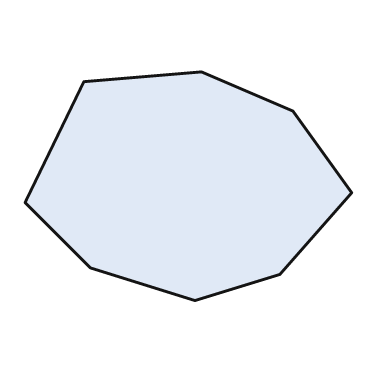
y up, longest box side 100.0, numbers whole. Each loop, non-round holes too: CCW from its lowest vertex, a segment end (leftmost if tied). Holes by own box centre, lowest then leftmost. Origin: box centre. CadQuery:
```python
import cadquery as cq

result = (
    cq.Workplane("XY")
    .moveTo(2.0, -35.0)
    .lineTo(28.0, -27.0)
    .lineTo(50.0, -2.0)
    .lineTo(32.0, 23.0)
    .lineTo(4.0, 35.0)
    .lineTo(-32.0, 32.0)
    .lineTo(-50.0, -5.0)
    .lineTo(-30.0, -25.0)
    .close()
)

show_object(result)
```